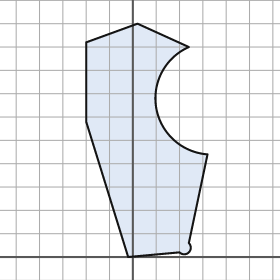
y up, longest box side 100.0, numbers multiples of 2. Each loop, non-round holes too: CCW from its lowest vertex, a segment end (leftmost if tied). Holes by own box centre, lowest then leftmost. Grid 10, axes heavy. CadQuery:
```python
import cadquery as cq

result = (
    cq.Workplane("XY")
    .moveTo(-2.0, 0.0)
    .lineTo(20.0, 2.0)
    .threePointArc((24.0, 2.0), (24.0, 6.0))
    .lineTo(32.0, 44.0)
    .threePointArc((10.0, 64.0), (24.0, 90.0))
    .lineTo(2.0, 100.0)
    .lineTo(-20.0, 92.0)
    .lineTo(-20.0, 58.0)
    .close()
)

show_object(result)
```